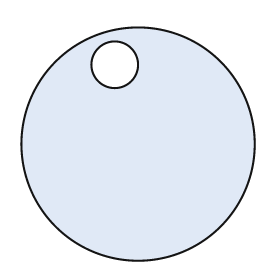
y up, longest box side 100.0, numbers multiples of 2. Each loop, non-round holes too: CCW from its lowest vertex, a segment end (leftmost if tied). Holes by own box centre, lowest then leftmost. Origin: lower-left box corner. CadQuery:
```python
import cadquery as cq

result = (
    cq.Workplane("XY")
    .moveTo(50.0, 50.0)
    .circle(50.0)
    .moveTo(40.0, 84.0)
    .circle(10.0)
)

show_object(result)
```